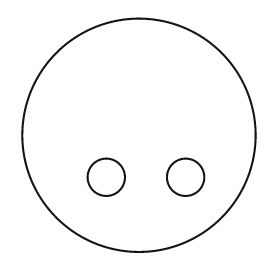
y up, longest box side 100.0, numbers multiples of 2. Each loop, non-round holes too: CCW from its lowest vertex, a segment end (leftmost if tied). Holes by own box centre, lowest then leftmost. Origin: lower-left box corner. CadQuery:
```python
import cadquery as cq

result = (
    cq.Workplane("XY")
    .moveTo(50.0, 50.0)
    .circle(50.0)
    .moveTo(36.0, 32.0)
    .circle(8.0)
    .moveTo(70.0, 32.0)
    .circle(8.0)
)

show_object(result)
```